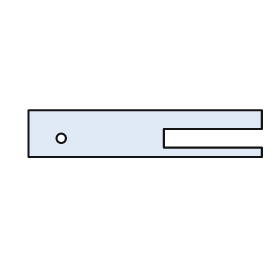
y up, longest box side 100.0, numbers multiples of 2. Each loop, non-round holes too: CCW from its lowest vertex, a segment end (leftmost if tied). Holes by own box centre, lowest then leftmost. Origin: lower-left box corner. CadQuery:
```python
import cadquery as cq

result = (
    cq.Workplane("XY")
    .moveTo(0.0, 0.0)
    .lineTo(100.0, 0.0)
    .lineTo(100.0, 4.0)
    .lineTo(58.0, 4.0)
    .lineTo(58.0, 12.0)
    .lineTo(100.0, 12.0)
    .lineTo(100.0, 20.0)
    .lineTo(0.0, 20.0)
    .close()
    .moveTo(14.0, 8.0)
    .circle(2.0)
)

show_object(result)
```